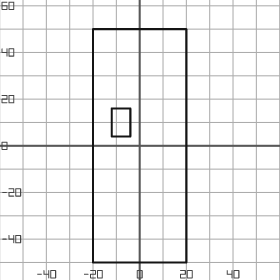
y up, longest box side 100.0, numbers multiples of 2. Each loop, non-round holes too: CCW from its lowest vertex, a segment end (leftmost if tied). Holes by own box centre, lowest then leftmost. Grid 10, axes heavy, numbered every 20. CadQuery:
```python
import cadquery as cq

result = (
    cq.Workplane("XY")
    .moveTo(-20.0, -50.0)
    .lineTo(20.0, -50.0)
    .lineTo(20.0, 50.0)
    .lineTo(-20.0, 50.0)
    .close()
    .moveTo(-12.0, 4.0)
    .lineTo(-4.0, 4.0)
    .lineTo(-4.0, 16.0)
    .lineTo(-12.0, 16.0)
    .close()
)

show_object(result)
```